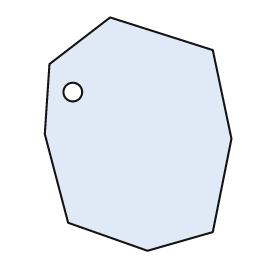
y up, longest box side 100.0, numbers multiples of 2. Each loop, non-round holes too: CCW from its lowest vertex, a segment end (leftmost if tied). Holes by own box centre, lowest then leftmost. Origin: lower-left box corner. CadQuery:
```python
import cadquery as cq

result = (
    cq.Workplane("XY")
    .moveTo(44.0, 0.0)
    .lineTo(72.0, 8.0)
    .lineTo(80.0, 48.0)
    .lineTo(72.0, 86.0)
    .lineTo(28.0, 100.0)
    .lineTo(2.0, 80.0)
    .lineTo(0.0, 50.0)
    .lineTo(10.0, 12.0)
    .close()
    .moveTo(12.0, 68.0)
    .circle(4.0)
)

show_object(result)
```